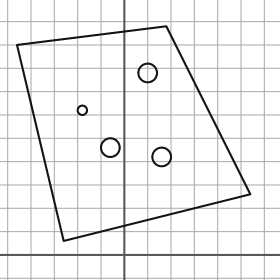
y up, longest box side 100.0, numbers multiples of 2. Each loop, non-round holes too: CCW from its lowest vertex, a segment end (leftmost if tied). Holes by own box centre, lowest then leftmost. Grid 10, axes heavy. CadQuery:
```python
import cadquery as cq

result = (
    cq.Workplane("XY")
    .moveTo(-26.0, 6.0)
    .lineTo(54.0, 26.0)
    .lineTo(18.0, 98.0)
    .lineTo(-46.0, 90.0)
    .close()
    .moveTo(16.0, 42.0)
    .circle(4.0)
    .moveTo(-6.0, 46.0)
    .circle(4.0)
    .moveTo(-18.0, 62.0)
    .circle(2.0)
    .moveTo(10.0, 78.0)
    .circle(4.0)
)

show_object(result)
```